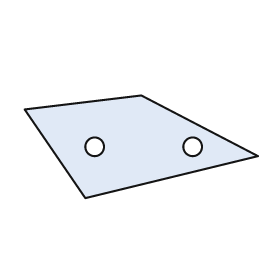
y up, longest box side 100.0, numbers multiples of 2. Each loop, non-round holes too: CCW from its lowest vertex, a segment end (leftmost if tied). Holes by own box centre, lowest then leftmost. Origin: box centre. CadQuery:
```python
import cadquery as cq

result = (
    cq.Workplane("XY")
    .moveTo(-24.0, -22.0)
    .lineTo(50.0, -4.0)
    .lineTo(0.0, 22.0)
    .lineTo(-50.0, 16.0)
    .close()
    .moveTo(-20.0, 0.0)
    .circle(4.0)
    .moveTo(22.0, 0.0)
    .circle(4.0)
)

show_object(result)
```